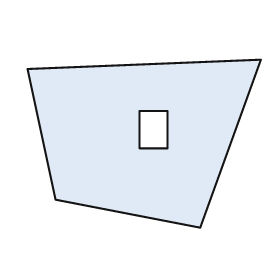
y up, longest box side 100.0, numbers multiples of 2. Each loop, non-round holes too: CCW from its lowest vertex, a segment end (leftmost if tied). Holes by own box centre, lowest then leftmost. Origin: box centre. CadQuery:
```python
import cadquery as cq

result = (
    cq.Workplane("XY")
    .moveTo(24.0, -36.0)
    .lineTo(50.0, 36.0)
    .lineTo(-50.0, 32.0)
    .lineTo(-38.0, -24.0)
    .close()
    .moveTo(-2.0, -2.0)
    .lineTo(10.0, -2.0)
    .lineTo(10.0, 14.0)
    .lineTo(-2.0, 14.0)
    .close()
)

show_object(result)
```